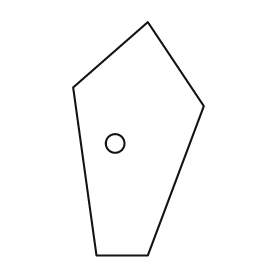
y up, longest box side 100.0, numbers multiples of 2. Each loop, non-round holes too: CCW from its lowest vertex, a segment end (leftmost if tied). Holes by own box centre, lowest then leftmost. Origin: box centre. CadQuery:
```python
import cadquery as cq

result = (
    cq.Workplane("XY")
    .moveTo(-18.0, -50.0)
    .lineTo(4.0, -50.0)
    .lineTo(28.0, 14.0)
    .lineTo(4.0, 50.0)
    .lineTo(-28.0, 22.0)
    .close()
    .moveTo(-10.0, -2.0)
    .circle(4.0)
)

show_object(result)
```